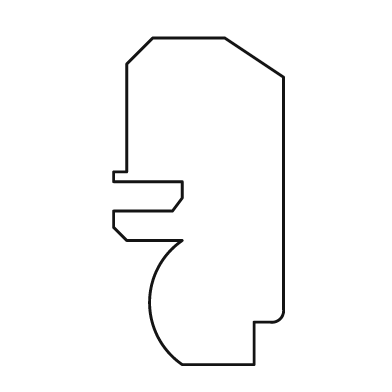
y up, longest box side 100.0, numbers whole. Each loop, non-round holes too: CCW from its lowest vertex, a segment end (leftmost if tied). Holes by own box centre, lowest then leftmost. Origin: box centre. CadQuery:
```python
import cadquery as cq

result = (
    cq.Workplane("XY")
    .moveTo(-5.0, -50.0)
    .lineTo(17.0, -50.0)
    .lineTo(17.0, -37.0)
    .lineTo(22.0, -37.0)
    .threePointArc((25.0, -36.0), (26.0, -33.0))
    .lineTo(26.0, 38.0)
    .lineTo(8.0, 50.0)
    .lineTo(-14.0, 50.0)
    .lineTo(-22.0, 42.0)
    .lineTo(-22.0, 9.0)
    .lineTo(-26.0, 9.0)
    .lineTo(-26.0, 6.0)
    .lineTo(-5.0, 6.0)
    .lineTo(-5.0, 1.0)
    .lineTo(-8.0, -3.0)
    .lineTo(-26.0, -3.0)
    .lineTo(-26.0, -8.0)
    .lineTo(-22.0, -12.0)
    .lineTo(-5.0, -12.0)
    .threePointArc((-15.0, -31.0), (-5.0, -50.0))
    .close()
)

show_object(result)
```